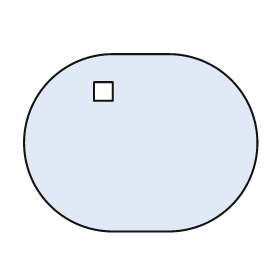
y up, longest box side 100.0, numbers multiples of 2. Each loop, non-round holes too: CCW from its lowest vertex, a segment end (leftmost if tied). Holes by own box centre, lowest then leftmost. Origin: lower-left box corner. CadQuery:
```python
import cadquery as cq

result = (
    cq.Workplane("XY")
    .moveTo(38.0, 0.0)
    .lineTo(62.0, 0.0)
    .threePointArc((100.0, 38.0), (62.0, 76.0))
    .lineTo(38.0, 76.0)
    .threePointArc((0.0, 38.0), (38.0, 0.0))
    .close()
    .moveTo(30.0, 56.0)
    .lineTo(38.0, 56.0)
    .lineTo(38.0, 64.0)
    .lineTo(30.0, 64.0)
    .close()
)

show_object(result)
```